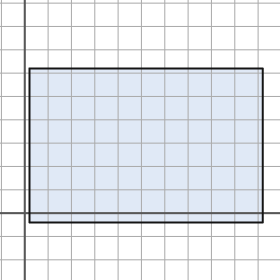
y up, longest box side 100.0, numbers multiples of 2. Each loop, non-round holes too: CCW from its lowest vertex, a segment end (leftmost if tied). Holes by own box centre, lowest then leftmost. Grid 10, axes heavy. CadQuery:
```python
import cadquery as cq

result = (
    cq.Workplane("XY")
    .moveTo(2.0, -4.0)
    .lineTo(102.0, -4.0)
    .lineTo(102.0, 62.0)
    .lineTo(2.0, 62.0)
    .close()
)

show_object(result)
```